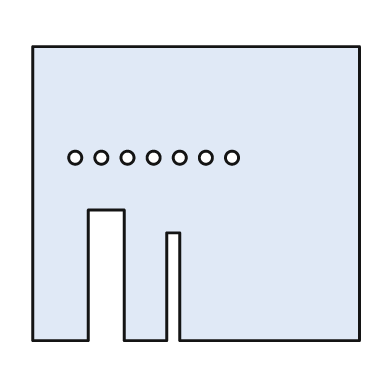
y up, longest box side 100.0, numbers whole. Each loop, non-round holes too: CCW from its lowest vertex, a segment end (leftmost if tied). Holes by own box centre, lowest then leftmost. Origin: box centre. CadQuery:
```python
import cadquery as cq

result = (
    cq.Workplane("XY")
    .moveTo(-50.0, -45.0)
    .lineTo(-33.0, -45.0)
    .lineTo(-33.0, -5.0)
    .lineTo(-22.0, -5.0)
    .lineTo(-22.0, -45.0)
    .lineTo(-9.0, -45.0)
    .lineTo(-9.0, -12.0)
    .lineTo(-5.0, -12.0)
    .lineTo(-5.0, -45.0)
    .lineTo(50.0, -45.0)
    .lineTo(50.0, 45.0)
    .lineTo(-50.0, 45.0)
    .close()
    .moveTo(-37.0, 11.0)
    .circle(2.0)
    .moveTo(-29.0, 11.0)
    .circle(2.0)
    .moveTo(-21.0, 11.0)
    .circle(2.0)
    .moveTo(-13.0, 11.0)
    .circle(2.0)
    .moveTo(-5.0, 11.0)
    .circle(2.0)
    .moveTo(3.0, 11.0)
    .circle(2.0)
    .moveTo(11.0, 11.0)
    .circle(2.0)
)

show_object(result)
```